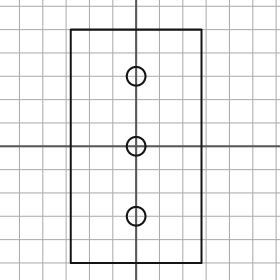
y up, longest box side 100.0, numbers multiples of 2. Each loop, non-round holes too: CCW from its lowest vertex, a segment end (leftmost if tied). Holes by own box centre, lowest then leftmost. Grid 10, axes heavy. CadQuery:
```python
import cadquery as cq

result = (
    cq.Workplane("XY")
    .moveTo(-28.0, -50.0)
    .lineTo(28.0, -50.0)
    .lineTo(28.0, 50.0)
    .lineTo(-28.0, 50.0)
    .close()
    .moveTo(0.0, -30.0)
    .circle(4.0)
    .moveTo(0.0, 0.0)
    .circle(4.0)
    .moveTo(0.0, 30.0)
    .circle(4.0)
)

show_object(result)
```